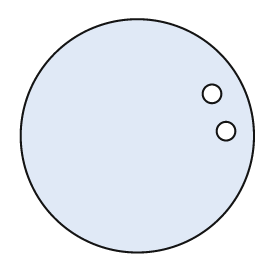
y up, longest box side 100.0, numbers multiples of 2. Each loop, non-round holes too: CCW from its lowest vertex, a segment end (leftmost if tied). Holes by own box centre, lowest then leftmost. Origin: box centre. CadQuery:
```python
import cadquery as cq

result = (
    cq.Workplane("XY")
    .moveTo(0.0, 0.0)
    .circle(50.0)
    .moveTo(38.0, 2.0)
    .circle(4.0)
    .moveTo(32.0, 18.0)
    .circle(4.0)
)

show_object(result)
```